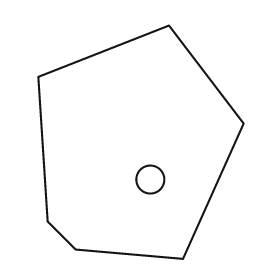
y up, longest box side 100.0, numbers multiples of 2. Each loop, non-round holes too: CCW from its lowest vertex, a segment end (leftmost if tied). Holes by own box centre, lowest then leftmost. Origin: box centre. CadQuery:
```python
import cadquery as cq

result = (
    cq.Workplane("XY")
    .moveTo(18.0, -50.0)
    .lineTo(44.0, 8.0)
    .lineTo(12.0, 50.0)
    .lineTo(-44.0, 28.0)
    .lineTo(-40.0, -34.0)
    .lineTo(-28.0, -46.0)
    .close()
    .moveTo(4.0, -16.0)
    .circle(6.0)
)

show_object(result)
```